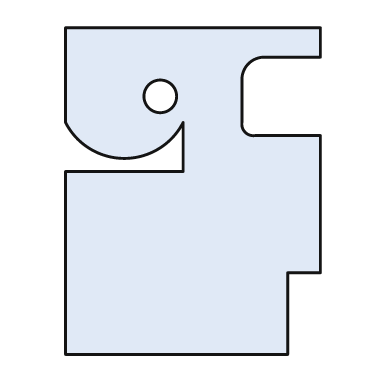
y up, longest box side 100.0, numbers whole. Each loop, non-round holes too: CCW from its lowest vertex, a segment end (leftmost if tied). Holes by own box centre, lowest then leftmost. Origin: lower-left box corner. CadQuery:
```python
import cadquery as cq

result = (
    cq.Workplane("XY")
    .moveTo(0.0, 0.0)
    .lineTo(68.0, 0.0)
    .lineTo(68.0, 25.0)
    .lineTo(78.0, 25.0)
    .lineTo(78.0, 67.0)
    .lineTo(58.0, 67.0)
    .threePointArc((55.0, 68.0), (54.0, 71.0))
    .lineTo(54.0, 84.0)
    .threePointArc((56.0, 89.0), (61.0, 91.0))
    .lineTo(78.0, 91.0)
    .lineTo(78.0, 100.0)
    .lineTo(0.0, 100.0)
    .lineTo(0.0, 71.0)
    .threePointArc((18.0, 60.0), (36.0, 71.0))
    .lineTo(36.0, 56.0)
    .lineTo(0.0, 56.0)
    .close()
    .moveTo(29.0, 79.0)
    .circle(5.0)
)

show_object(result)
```